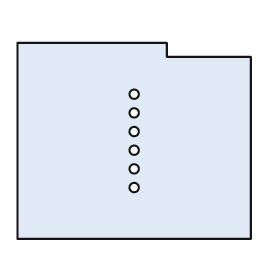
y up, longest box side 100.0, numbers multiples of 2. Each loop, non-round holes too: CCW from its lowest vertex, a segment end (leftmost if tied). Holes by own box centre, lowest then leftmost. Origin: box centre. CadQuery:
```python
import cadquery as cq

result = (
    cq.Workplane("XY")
    .moveTo(-50.0, -42.0)
    .lineTo(50.0, -42.0)
    .lineTo(50.0, 36.0)
    .lineTo(14.0, 36.0)
    .lineTo(14.0, 42.0)
    .lineTo(-50.0, 42.0)
    .close()
    .moveTo(0.0, -20.0)
    .circle(2.0)
    .moveTo(0.0, -12.0)
    .circle(2.0)
    .moveTo(0.0, -4.0)
    .circle(2.0)
    .moveTo(0.0, 4.0)
    .circle(2.0)
    .moveTo(0.0, 12.0)
    .circle(2.0)
    .moveTo(0.0, 20.0)
    .circle(2.0)
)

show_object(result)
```